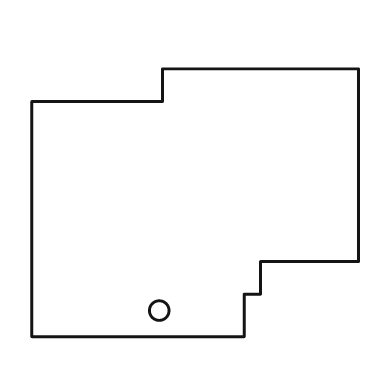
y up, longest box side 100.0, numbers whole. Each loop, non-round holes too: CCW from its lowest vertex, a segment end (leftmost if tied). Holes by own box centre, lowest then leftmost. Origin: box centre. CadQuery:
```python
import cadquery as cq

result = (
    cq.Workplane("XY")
    .moveTo(-50.0, -41.0)
    .lineTo(15.0, -41.0)
    .lineTo(15.0, -28.0)
    .lineTo(20.0, -28.0)
    .lineTo(20.0, -18.0)
    .lineTo(50.0, -18.0)
    .lineTo(50.0, 41.0)
    .lineTo(-10.0, 41.0)
    .lineTo(-10.0, 31.0)
    .lineTo(-50.0, 31.0)
    .close()
    .moveTo(-11.0, -33.0)
    .circle(3.0)
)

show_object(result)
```